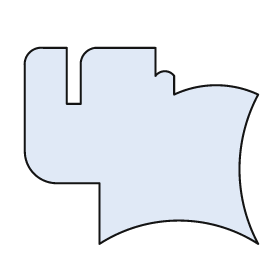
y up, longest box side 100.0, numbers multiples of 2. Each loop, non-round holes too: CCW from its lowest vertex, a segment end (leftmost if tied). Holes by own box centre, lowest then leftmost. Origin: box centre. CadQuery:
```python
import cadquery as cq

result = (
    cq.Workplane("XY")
    .moveTo(-18.0, -42.0)
    .threePointArc((16.0, -32.0), (50.0, -42.0))
    .threePointArc((42.0, -10.0), (50.0, 22.0))
    .threePointArc((32.0, 26.0), (14.0, 22.0))
    .lineTo(14.0, 30.0)
    .threePointArc((10.0, 32.0), (6.0, 30.0))
    .lineTo(6.0, 42.0)
    .lineTo(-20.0, 42.0)
    .threePointArc((-24.0, 40.0), (-26.0, 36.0))
    .lineTo(-26.0, 18.0)
    .lineTo(-32.0, 18.0)
    .lineTo(-32.0, 42.0)
    .lineTo(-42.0, 42.0)
    .threePointArc((-48.0, 40.0), (-50.0, 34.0))
    .lineTo(-50.0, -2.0)
    .threePointArc((-46.0, -12.0), (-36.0, -16.0))
    .lineTo(-18.0, -16.0)
    .close()
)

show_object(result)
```